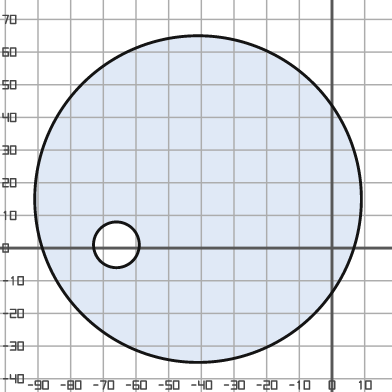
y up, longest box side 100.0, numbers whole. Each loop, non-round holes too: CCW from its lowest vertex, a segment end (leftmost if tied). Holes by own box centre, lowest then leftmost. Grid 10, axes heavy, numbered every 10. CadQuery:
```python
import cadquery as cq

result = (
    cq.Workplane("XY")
    .moveTo(-41.0, 15.0)
    .circle(50.0)
    .moveTo(-66.0, 1.0)
    .circle(7.0)
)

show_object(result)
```